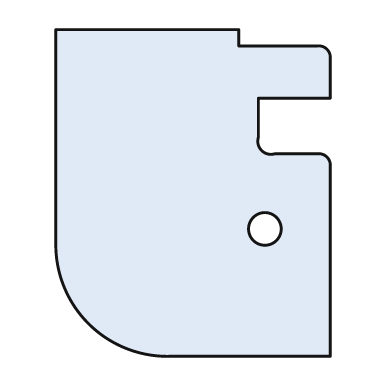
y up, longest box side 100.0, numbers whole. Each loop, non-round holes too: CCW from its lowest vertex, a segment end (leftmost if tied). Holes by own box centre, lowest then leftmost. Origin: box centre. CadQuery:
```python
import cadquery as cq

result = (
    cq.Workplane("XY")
    .moveTo(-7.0, -50.0)
    .lineTo(42.0, -50.0)
    .lineTo(42.0, 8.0)
    .threePointArc((41.0, 11.0), (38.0, 12.0))
    .lineTo(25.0, 12.0)
    .threePointArc((21.0, 13.0), (20.0, 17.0))
    .lineTo(20.0, 29.0)
    .lineTo(42.0, 29.0)
    .lineTo(42.0, 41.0)
    .threePointArc((41.0, 44.0), (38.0, 45.0))
    .lineTo(14.0, 45.0)
    .lineTo(14.0, 50.0)
    .lineTo(-42.0, 50.0)
    .lineTo(-42.0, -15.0)
    .threePointArc((-32.0, -40.0), (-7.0, -50.0))
    .close()
    .moveTo(22.0, -11.0)
    .circle(5.0)
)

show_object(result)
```